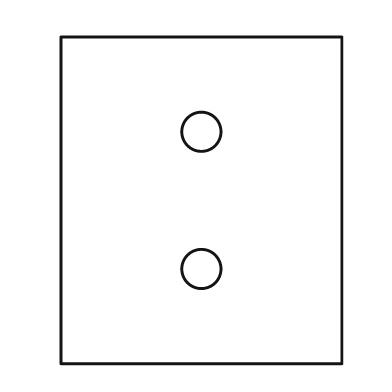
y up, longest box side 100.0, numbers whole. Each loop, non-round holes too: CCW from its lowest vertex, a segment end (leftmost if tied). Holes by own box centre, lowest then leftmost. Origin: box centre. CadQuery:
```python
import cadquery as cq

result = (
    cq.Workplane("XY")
    .moveTo(-43.0, -50.0)
    .lineTo(43.0, -50.0)
    .lineTo(43.0, 50.0)
    .lineTo(-43.0, 50.0)
    .close()
    .moveTo(0.0, -21.0)
    .circle(6.0)
    .moveTo(0.0, 21.0)
    .circle(6.0)
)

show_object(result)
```